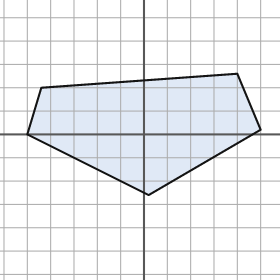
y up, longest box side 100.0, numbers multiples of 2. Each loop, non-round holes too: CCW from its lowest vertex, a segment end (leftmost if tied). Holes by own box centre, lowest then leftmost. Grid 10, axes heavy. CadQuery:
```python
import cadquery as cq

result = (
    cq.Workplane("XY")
    .moveTo(2.0, -26.0)
    .lineTo(50.0, 2.0)
    .lineTo(40.0, 26.0)
    .lineTo(-44.0, 20.0)
    .lineTo(-50.0, 0.0)
    .close()
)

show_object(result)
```